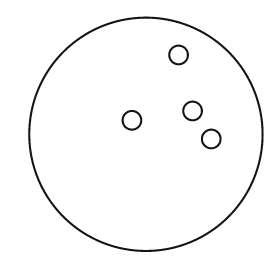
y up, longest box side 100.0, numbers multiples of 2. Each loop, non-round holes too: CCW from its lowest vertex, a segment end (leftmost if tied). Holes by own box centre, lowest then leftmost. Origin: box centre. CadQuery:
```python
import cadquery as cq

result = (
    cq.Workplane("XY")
    .moveTo(0.0, 0.0)
    .circle(50.0)
    .moveTo(28.0, -2.0)
    .circle(4.0)
    .moveTo(-6.0, 6.0)
    .circle(4.0)
    .moveTo(20.0, 10.0)
    .circle(4.0)
    .moveTo(14.0, 34.0)
    .circle(4.0)
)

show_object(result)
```